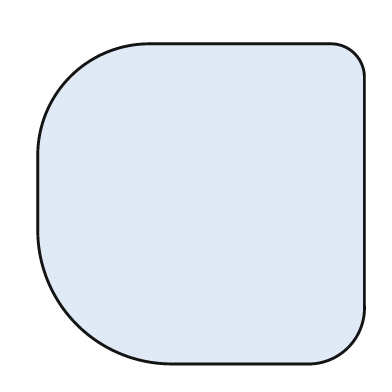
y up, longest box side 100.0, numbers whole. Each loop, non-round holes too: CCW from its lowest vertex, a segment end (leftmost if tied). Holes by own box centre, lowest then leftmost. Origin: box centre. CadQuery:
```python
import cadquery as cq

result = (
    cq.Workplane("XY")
    .moveTo(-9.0, -49.0)
    .lineTo(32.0, -49.0)
    .threePointArc((45.0, -44.0), (50.0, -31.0))
    .lineTo(50.0, 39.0)
    .threePointArc((47.0, 46.0), (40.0, 49.0))
    .lineTo(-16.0, 49.0)
    .threePointArc((-40.0, 39.0), (-50.0, 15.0))
    .lineTo(-50.0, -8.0)
    .threePointArc((-38.0, -37.0), (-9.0, -49.0))
    .close()
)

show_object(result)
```